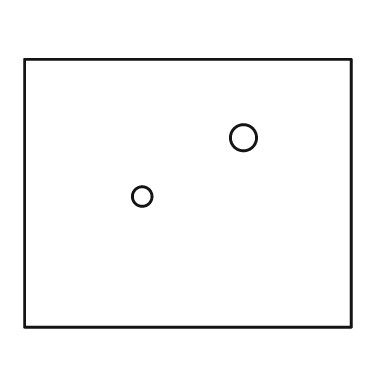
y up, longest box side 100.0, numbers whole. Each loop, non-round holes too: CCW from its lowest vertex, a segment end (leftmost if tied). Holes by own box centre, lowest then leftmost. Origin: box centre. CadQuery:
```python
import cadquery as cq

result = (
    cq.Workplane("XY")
    .moveTo(-50.0, -41.0)
    .lineTo(50.0, -41.0)
    .lineTo(50.0, 41.0)
    .lineTo(-50.0, 41.0)
    .close()
    .moveTo(-14.0, -1.0)
    .circle(3.0)
    .moveTo(17.0, 17.0)
    .circle(4.0)
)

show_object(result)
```